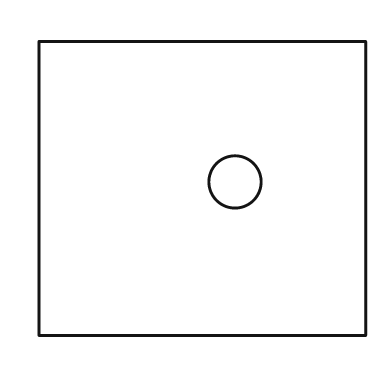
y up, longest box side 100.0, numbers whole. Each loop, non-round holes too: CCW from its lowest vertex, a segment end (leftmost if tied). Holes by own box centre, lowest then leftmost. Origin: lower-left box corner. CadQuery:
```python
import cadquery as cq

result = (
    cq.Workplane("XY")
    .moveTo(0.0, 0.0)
    .lineTo(100.0, 0.0)
    .lineTo(100.0, 90.0)
    .lineTo(0.0, 90.0)
    .close()
    .moveTo(60.0, 47.0)
    .circle(8.0)
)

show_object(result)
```